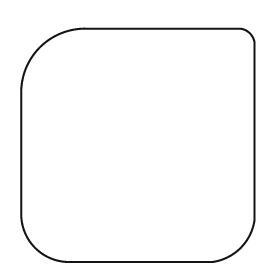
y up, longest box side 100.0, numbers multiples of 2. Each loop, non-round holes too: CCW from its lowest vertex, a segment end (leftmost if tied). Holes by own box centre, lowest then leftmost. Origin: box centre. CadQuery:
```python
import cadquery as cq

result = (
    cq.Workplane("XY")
    .moveTo(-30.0, -50.0)
    .lineTo(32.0, -50.0)
    .threePointArc((44.0, -44.0), (50.0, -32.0))
    .lineTo(50.0, 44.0)
    .threePointArc((48.0, 48.0), (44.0, 50.0))
    .lineTo(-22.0, 50.0)
    .threePointArc((-42.0, 42.0), (-50.0, 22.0))
    .lineTo(-50.0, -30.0)
    .threePointArc((-44.0, -44.0), (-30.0, -50.0))
    .close()
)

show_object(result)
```